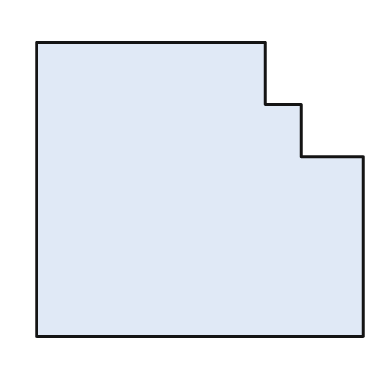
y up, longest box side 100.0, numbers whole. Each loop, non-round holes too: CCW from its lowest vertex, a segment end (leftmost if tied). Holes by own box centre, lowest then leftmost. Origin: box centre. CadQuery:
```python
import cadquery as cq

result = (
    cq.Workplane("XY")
    .moveTo(-50.0, -45.0)
    .lineTo(50.0, -45.0)
    .lineTo(50.0, 10.0)
    .lineTo(31.0, 10.0)
    .lineTo(31.0, 26.0)
    .lineTo(20.0, 26.0)
    .lineTo(20.0, 45.0)
    .lineTo(-50.0, 45.0)
    .close()
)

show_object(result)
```